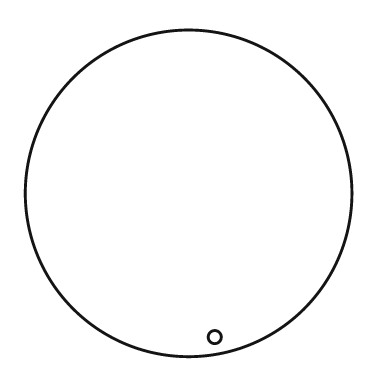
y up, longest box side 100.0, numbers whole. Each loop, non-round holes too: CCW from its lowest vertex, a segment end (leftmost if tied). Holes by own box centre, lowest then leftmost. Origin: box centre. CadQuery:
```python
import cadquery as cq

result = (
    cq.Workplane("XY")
    .moveTo(0.0, 0.0)
    .circle(50.0)
    .moveTo(8.0, -44.0)
    .circle(2.0)
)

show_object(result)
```